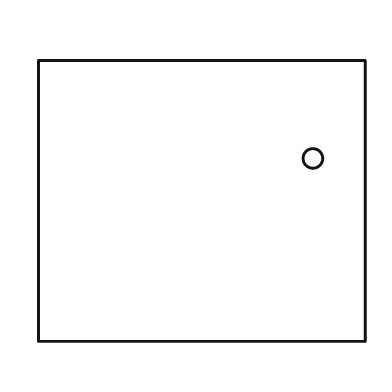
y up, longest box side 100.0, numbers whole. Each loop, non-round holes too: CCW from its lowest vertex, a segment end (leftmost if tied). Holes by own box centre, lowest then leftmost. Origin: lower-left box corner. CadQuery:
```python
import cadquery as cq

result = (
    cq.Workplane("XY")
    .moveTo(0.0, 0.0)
    .lineTo(100.0, 0.0)
    .lineTo(100.0, 86.0)
    .lineTo(0.0, 86.0)
    .close()
    .moveTo(84.0, 56.0)
    .circle(3.0)
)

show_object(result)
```